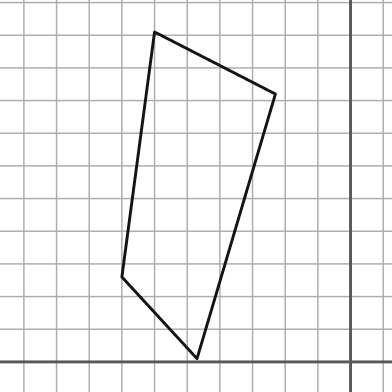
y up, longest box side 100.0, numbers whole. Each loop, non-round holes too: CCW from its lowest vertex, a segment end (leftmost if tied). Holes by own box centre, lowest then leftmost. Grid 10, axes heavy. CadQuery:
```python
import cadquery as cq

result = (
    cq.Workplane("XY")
    .moveTo(-47.0, 1.0)
    .lineTo(-23.0, 82.0)
    .lineTo(-60.0, 101.0)
    .lineTo(-70.0, 26.0)
    .close()
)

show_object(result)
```